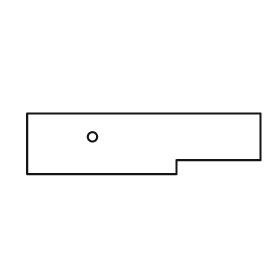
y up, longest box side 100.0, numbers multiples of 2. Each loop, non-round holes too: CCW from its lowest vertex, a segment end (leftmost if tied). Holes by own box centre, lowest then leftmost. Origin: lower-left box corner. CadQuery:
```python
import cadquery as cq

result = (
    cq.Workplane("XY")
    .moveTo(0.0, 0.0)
    .lineTo(64.0, 0.0)
    .lineTo(64.0, 6.0)
    .lineTo(100.0, 6.0)
    .lineTo(100.0, 26.0)
    .lineTo(0.0, 26.0)
    .close()
    .moveTo(28.0, 16.0)
    .circle(2.0)
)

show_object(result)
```